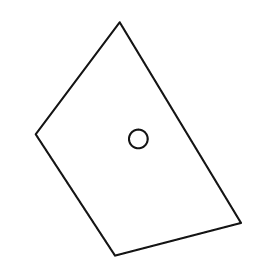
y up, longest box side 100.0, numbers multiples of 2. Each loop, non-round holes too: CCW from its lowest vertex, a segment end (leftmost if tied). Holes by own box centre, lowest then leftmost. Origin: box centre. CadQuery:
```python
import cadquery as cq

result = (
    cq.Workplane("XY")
    .moveTo(-10.0, -50.0)
    .lineTo(44.0, -36.0)
    .lineTo(-8.0, 50.0)
    .lineTo(-44.0, 2.0)
    .close()
    .moveTo(0.0, 0.0)
    .circle(4.0)
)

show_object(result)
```